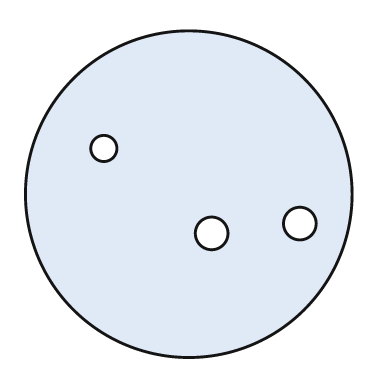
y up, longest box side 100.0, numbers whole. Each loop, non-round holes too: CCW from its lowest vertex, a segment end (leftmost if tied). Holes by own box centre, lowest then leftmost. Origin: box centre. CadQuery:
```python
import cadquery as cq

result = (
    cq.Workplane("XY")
    .moveTo(0.0, 0.0)
    .circle(50.0)
    .moveTo(7.0, -12.0)
    .circle(5.0)
    .moveTo(34.0, -9.0)
    .circle(5.0)
    .moveTo(-26.0, 14.0)
    .circle(4.0)
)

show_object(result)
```